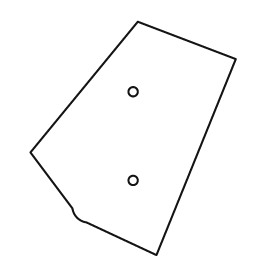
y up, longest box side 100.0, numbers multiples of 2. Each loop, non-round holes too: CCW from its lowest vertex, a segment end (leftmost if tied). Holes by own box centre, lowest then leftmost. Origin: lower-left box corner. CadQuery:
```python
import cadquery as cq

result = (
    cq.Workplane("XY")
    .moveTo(54.0, 0.0)
    .lineTo(88.0, 84.0)
    .lineTo(46.0, 100.0)
    .lineTo(0.0, 44.0)
    .lineTo(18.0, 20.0)
    .threePointArc((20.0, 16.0), (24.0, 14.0))
    .close()
    .moveTo(44.0, 32.0)
    .circle(2.0)
    .moveTo(44.0, 70.0)
    .circle(2.0)
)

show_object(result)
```